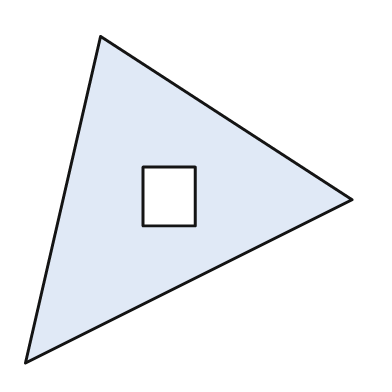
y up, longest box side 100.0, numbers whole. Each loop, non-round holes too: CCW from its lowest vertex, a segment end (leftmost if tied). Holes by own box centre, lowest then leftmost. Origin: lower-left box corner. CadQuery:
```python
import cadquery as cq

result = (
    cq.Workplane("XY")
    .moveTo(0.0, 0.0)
    .lineTo(100.0, 50.0)
    .lineTo(23.0, 100.0)
    .close()
    .moveTo(36.0, 42.0)
    .lineTo(52.0, 42.0)
    .lineTo(52.0, 60.0)
    .lineTo(36.0, 60.0)
    .close()
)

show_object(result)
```